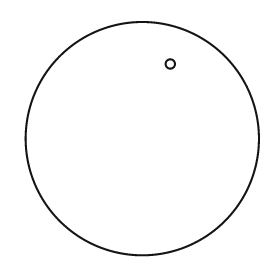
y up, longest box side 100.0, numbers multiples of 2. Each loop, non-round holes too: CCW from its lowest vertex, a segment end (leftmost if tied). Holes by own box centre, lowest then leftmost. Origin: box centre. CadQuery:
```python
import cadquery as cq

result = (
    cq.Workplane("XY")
    .moveTo(0.0, 0.0)
    .circle(50.0)
    .moveTo(12.0, 32.0)
    .circle(2.0)
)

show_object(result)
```